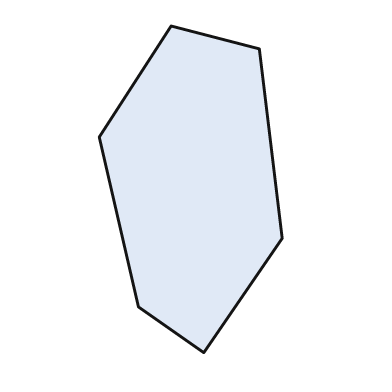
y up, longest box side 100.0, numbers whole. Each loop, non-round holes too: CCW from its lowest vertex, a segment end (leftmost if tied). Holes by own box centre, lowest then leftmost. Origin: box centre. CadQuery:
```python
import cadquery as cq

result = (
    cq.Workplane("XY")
    .moveTo(4.0, -50.0)
    .lineTo(28.0, -15.0)
    .lineTo(21.0, 43.0)
    .lineTo(-6.0, 50.0)
    .lineTo(-28.0, 16.0)
    .lineTo(-16.0, -36.0)
    .close()
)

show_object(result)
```